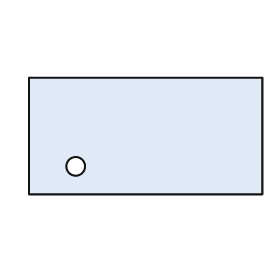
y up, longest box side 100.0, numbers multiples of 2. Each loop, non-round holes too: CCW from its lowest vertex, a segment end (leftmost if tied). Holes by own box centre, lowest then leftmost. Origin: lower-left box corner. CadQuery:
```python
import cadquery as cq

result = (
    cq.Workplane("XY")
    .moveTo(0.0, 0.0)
    .lineTo(100.0, 0.0)
    .lineTo(100.0, 50.0)
    .lineTo(0.0, 50.0)
    .close()
    .moveTo(20.0, 12.0)
    .circle(4.0)
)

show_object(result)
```